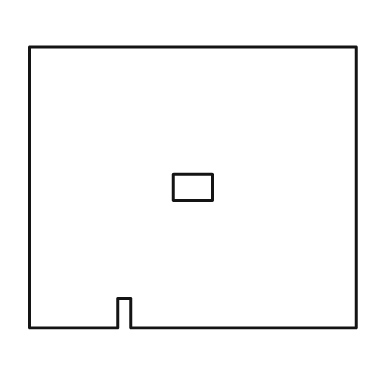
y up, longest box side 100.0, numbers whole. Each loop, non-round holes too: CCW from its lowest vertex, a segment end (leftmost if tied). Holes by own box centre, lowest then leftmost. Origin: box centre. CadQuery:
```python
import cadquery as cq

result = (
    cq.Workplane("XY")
    .moveTo(-50.0, -43.0)
    .lineTo(-23.0, -43.0)
    .lineTo(-23.0, -34.0)
    .lineTo(-19.0, -34.0)
    .lineTo(-19.0, -43.0)
    .lineTo(50.0, -43.0)
    .lineTo(50.0, 43.0)
    .lineTo(-50.0, 43.0)
    .close()
    .moveTo(-6.0, -4.0)
    .lineTo(6.0, -4.0)
    .lineTo(6.0, 4.0)
    .lineTo(-6.0, 4.0)
    .close()
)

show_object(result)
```